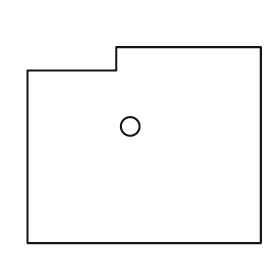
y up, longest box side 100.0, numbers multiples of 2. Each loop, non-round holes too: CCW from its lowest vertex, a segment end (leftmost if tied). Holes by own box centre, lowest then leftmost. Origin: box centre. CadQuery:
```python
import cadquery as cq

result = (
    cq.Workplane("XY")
    .moveTo(-50.0, -42.0)
    .lineTo(50.0, -42.0)
    .lineTo(50.0, 42.0)
    .lineTo(-12.0, 42.0)
    .lineTo(-12.0, 32.0)
    .lineTo(-50.0, 32.0)
    .close()
    .moveTo(-6.0, 8.0)
    .circle(4.0)
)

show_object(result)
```